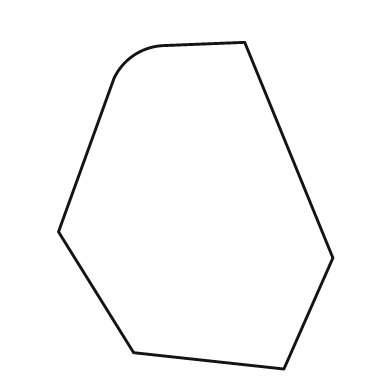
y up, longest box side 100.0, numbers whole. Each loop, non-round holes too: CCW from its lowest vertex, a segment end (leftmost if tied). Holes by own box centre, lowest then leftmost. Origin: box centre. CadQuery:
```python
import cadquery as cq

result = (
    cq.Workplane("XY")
    .moveTo(27.0, -50.0)
    .lineTo(42.0, -16.0)
    .lineTo(15.0, 50.0)
    .lineTo(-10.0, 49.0)
    .threePointArc((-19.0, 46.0), (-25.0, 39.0))
    .lineTo(-42.0, -8.0)
    .lineTo(-19.0, -45.0)
    .close()
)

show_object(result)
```